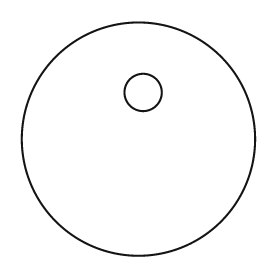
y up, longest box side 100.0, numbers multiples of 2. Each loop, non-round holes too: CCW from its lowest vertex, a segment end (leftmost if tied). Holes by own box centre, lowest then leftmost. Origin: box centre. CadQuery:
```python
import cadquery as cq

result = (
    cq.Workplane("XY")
    .moveTo(0.0, 0.0)
    .circle(50.0)
    .moveTo(2.0, 20.0)
    .circle(8.0)
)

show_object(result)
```